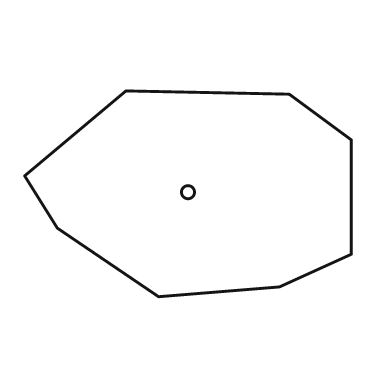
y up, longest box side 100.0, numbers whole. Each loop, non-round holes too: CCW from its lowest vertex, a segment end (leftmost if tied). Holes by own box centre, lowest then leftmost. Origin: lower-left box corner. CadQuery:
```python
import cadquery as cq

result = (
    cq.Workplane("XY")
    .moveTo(41.0, 0.0)
    .lineTo(78.0, 3.0)
    .lineTo(100.0, 13.0)
    .lineTo(100.0, 48.0)
    .lineTo(81.0, 62.0)
    .lineTo(31.0, 63.0)
    .lineTo(0.0, 37.0)
    .lineTo(10.0, 21.0)
    .close()
    .moveTo(50.0, 32.0)
    .circle(2.0)
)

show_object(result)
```